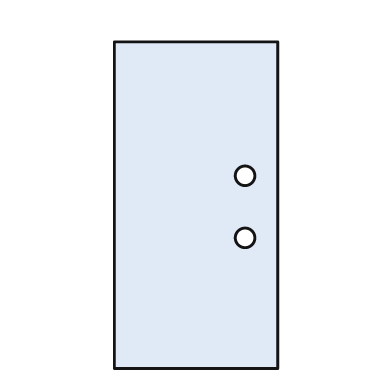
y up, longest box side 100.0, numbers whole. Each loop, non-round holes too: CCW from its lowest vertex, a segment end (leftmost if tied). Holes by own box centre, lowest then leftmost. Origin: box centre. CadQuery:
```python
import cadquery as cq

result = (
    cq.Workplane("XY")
    .moveTo(-25.0, -50.0)
    .lineTo(25.0, -50.0)
    .lineTo(25.0, 50.0)
    .lineTo(-25.0, 50.0)
    .close()
    .moveTo(15.0, -10.0)
    .circle(3.0)
    .moveTo(15.0, 9.0)
    .circle(3.0)
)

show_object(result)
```